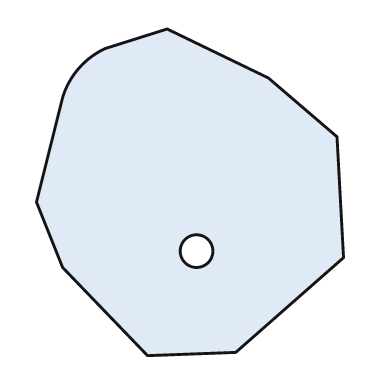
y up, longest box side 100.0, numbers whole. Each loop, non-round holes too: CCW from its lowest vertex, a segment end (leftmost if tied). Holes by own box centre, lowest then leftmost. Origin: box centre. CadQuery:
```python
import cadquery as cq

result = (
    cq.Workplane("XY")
    .moveTo(-13.0, -50.0)
    .lineTo(14.0, -49.0)
    .lineTo(47.0, -20.0)
    .lineTo(45.0, 17.0)
    .lineTo(24.0, 35.0)
    .lineTo(-7.0, 50.0)
    .lineTo(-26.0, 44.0)
    .threePointArc((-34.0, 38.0), (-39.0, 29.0))
    .lineTo(-47.0, -3.0)
    .lineTo(-39.0, -23.0)
    .close()
    .moveTo(2.0, -18.0)
    .circle(5.0)
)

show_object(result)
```